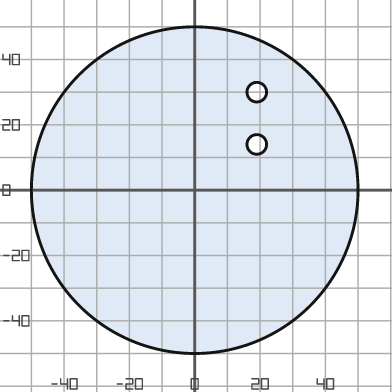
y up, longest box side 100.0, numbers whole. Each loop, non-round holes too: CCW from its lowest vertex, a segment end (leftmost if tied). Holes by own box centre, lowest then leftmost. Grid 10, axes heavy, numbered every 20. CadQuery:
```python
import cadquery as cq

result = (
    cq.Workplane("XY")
    .moveTo(0.0, 0.0)
    .circle(50.0)
    .moveTo(19.0, 14.0)
    .circle(3.0)
    .moveTo(19.0, 30.0)
    .circle(3.0)
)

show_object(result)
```